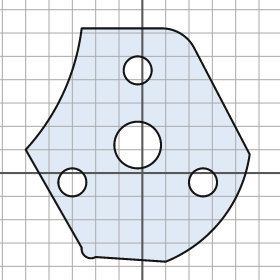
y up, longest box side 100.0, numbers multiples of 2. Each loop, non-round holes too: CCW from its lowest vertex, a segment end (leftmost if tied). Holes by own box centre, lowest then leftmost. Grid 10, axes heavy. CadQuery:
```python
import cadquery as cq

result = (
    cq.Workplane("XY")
    .moveTo(10.0, -38.0)
    .threePointArc((34.0, -20.0), (46.0, 8.0))
    .lineTo(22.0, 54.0)
    .threePointArc((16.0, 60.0), (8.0, 62.0))
    .lineTo(-26.0, 62.0)
    .threePointArc((-34.0, 34.0), (-50.0, 10.0))
    .lineTo(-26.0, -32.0)
    .threePointArc((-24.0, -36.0), (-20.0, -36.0))
    .close()
    .moveTo(-30.0, -4.0)
    .circle(6.0)
    .moveTo(26.0, -4.0)
    .circle(6.0)
    .moveTo(-2.0, 12.0)
    .circle(10.0)
    .moveTo(-2.0, 44.0)
    .circle(6.0)
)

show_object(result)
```